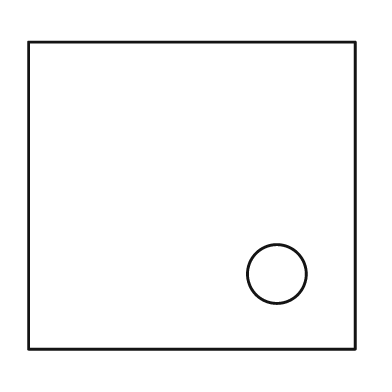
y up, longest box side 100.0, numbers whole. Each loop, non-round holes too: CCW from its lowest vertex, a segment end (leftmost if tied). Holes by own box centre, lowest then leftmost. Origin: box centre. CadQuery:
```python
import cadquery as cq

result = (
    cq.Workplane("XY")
    .moveTo(-50.0, -47.0)
    .lineTo(50.0, -47.0)
    .lineTo(50.0, 47.0)
    .lineTo(-50.0, 47.0)
    .close()
    .moveTo(26.0, -24.0)
    .circle(9.0)
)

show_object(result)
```